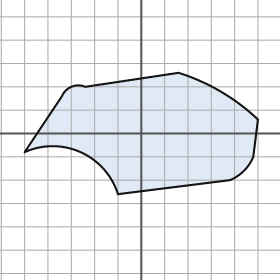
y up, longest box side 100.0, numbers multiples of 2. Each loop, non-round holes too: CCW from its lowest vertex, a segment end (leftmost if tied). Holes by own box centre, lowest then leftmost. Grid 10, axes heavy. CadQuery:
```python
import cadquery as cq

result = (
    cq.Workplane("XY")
    .moveTo(-10.0, -26.0)
    .lineTo(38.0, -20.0)
    .threePointArc((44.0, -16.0), (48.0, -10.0))
    .lineTo(50.0, 6.0)
    .threePointArc((34.0, 18.0), (16.0, 26.0))
    .lineTo(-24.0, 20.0)
    .threePointArc((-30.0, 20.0), (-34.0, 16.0))
    .lineTo(-50.0, -8.0)
    .threePointArc((-26.0, -8.0), (-10.0, -26.0))
    .close()
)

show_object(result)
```